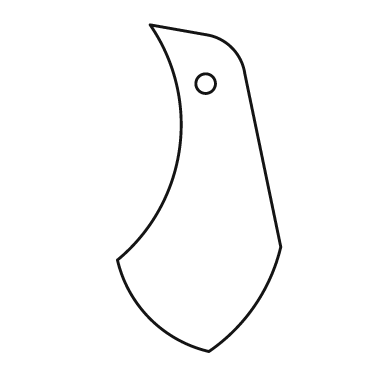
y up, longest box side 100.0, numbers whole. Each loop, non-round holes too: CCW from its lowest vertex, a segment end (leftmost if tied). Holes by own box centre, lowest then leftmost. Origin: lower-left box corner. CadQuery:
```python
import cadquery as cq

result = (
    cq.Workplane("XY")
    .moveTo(28.0, 0.0)
    .threePointArc((42.0, 14.0), (50.0, 32.0))
    .lineTo(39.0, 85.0)
    .threePointArc((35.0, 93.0), (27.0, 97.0))
    .lineTo(10.0, 100.0)
    .threePointArc((19.0, 62.0), (0.0, 28.0))
    .threePointArc((10.0, 10.0), (28.0, 0.0))
    .close()
    .moveTo(27.0, 82.0)
    .circle(3.0)
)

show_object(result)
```